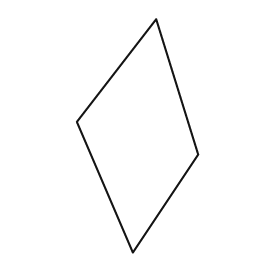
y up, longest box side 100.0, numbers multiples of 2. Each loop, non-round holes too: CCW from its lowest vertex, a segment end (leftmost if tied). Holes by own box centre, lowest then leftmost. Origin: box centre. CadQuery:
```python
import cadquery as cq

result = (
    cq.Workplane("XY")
    .moveTo(-2.0, -50.0)
    .lineTo(26.0, -8.0)
    .lineTo(8.0, 50.0)
    .lineTo(-26.0, 6.0)
    .close()
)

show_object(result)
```